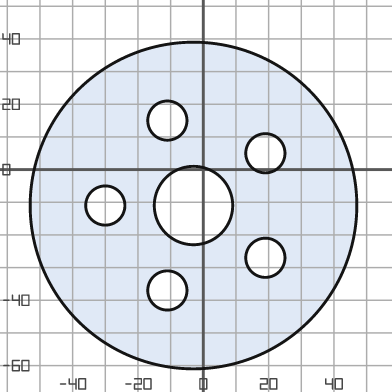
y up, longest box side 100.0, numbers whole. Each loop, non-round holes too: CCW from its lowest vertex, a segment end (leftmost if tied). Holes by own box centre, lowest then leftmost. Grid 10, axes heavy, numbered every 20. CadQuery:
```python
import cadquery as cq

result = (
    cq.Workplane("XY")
    .moveTo(-3.0, -11.0)
    .circle(50.0)
    .moveTo(-11.0, -37.0)
    .circle(6.0)
    .moveTo(19.0, -27.0)
    .circle(6.0)
    .moveTo(-30.0, -11.0)
    .circle(6.0)
    .moveTo(-3.0, -11.0)
    .circle(12.0)
    .moveTo(19.0, 5.0)
    .circle(6.0)
    .moveTo(-11.0, 15.0)
    .circle(6.0)
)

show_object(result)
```